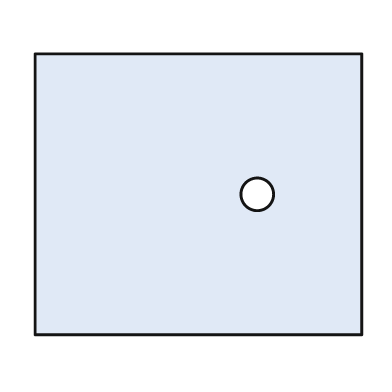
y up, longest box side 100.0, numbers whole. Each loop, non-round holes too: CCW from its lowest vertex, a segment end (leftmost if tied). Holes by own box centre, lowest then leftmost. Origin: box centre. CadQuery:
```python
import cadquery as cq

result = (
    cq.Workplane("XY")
    .moveTo(-50.0, -43.0)
    .lineTo(50.0, -43.0)
    .lineTo(50.0, 43.0)
    .lineTo(-50.0, 43.0)
    .close()
    .moveTo(18.0, 0.0)
    .circle(5.0)
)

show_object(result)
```